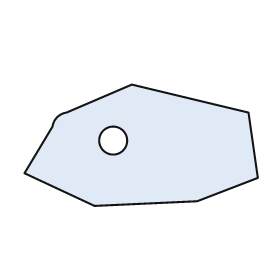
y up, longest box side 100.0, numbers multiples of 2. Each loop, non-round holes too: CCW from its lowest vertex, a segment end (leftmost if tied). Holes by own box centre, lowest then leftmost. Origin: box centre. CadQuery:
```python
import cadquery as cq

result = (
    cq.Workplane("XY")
    .moveTo(-20.0, -26.0)
    .lineTo(24.0, -24.0)
    .lineTo(50.0, -14.0)
    .lineTo(46.0, 14.0)
    .lineTo(-4.0, 26.0)
    .lineTo(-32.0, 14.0)
    .threePointArc((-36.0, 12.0), (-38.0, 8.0))
    .lineTo(-50.0, -12.0)
    .close()
    .moveTo(-12.0, 2.0)
    .circle(6.0)
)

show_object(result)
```